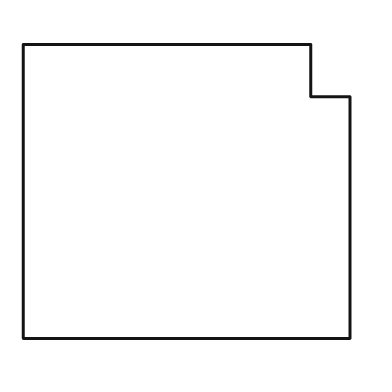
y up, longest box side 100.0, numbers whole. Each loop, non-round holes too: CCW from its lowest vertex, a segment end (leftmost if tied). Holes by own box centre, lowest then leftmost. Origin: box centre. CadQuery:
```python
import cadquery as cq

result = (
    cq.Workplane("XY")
    .moveTo(-50.0, -45.0)
    .lineTo(50.0, -45.0)
    .lineTo(50.0, 29.0)
    .lineTo(38.0, 29.0)
    .lineTo(38.0, 45.0)
    .lineTo(-50.0, 45.0)
    .close()
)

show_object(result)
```